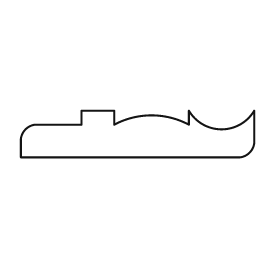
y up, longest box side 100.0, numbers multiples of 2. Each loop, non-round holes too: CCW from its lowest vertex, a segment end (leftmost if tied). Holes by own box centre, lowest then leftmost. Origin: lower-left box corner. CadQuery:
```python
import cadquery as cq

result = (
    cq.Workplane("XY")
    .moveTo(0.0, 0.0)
    .lineTo(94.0, 0.0)
    .threePointArc((98.0, 2.0), (100.0, 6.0))
    .lineTo(100.0, 20.0)
    .threePointArc((86.0, 12.0), (72.0, 20.0))
    .lineTo(72.0, 14.0)
    .threePointArc((56.0, 18.0), (40.0, 14.0))
    .lineTo(40.0, 20.0)
    .lineTo(26.0, 20.0)
    .lineTo(26.0, 14.0)
    .lineTo(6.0, 14.0)
    .threePointArc((2.0, 12.0), (0.0, 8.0))
    .close()
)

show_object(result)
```